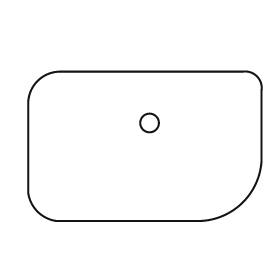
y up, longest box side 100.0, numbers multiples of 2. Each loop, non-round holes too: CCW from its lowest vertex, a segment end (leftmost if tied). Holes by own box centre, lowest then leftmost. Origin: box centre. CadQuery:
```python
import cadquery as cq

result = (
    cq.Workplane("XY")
    .moveTo(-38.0, -32.0)
    .lineTo(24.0, -32.0)
    .threePointArc((42.0, -24.0), (50.0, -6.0))
    .lineTo(50.0, 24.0)
    .threePointArc((48.0, 30.0), (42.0, 32.0))
    .lineTo(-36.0, 32.0)
    .threePointArc((-46.0, 28.0), (-50.0, 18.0))
    .lineTo(-50.0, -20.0)
    .threePointArc((-46.0, -28.0), (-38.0, -32.0))
    .close()
    .moveTo(2.0, 10.0)
    .circle(4.0)
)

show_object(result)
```